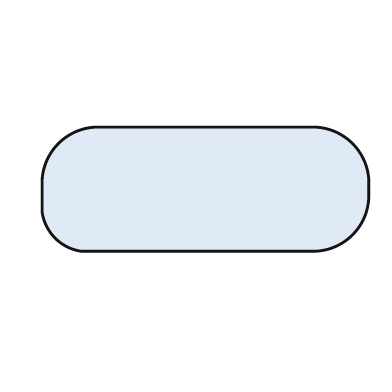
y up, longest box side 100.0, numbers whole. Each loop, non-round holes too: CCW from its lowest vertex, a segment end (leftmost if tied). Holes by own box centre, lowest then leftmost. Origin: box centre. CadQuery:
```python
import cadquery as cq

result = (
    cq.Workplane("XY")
    .moveTo(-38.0, -19.0)
    .lineTo(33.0, -19.0)
    .threePointArc((45.0, -14.0), (50.0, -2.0))
    .lineTo(50.0, 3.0)
    .threePointArc((45.0, 14.0), (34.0, 19.0))
    .lineTo(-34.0, 19.0)
    .threePointArc((-45.0, 14.0), (-50.0, 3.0))
    .lineTo(-50.0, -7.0)
    .threePointArc((-46.0, -15.0), (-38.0, -19.0))
    .close()
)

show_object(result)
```